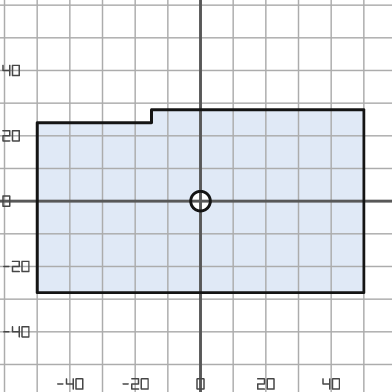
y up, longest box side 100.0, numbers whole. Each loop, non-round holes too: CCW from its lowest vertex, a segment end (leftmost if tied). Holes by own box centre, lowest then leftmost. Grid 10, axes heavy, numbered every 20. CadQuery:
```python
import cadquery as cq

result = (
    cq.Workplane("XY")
    .moveTo(-50.0, -28.0)
    .lineTo(50.0, -28.0)
    .lineTo(50.0, 28.0)
    .lineTo(-15.0, 28.0)
    .lineTo(-15.0, 24.0)
    .lineTo(-50.0, 24.0)
    .close()
    .moveTo(0.0, 0.0)
    .circle(3.0)
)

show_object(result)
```